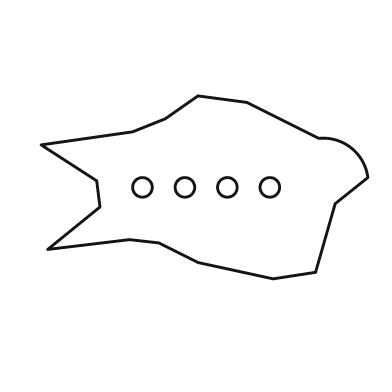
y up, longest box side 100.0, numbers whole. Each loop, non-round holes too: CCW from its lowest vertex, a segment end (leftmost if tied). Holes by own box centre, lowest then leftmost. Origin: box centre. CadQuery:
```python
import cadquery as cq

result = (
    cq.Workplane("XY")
    .moveTo(21.0, -28.0)
    .lineTo(34.0, -26.0)
    .lineTo(40.0, -5.0)
    .lineTo(50.0, 3.0)
    .threePointArc((45.0, 12.0), (35.0, 15.0))
    .lineTo(13.0, 26.0)
    .lineTo(-2.0, 28.0)
    .lineTo(-12.0, 21.0)
    .lineTo(-22.0, 17.0)
    .lineTo(-50.0, 13.0)
    .lineTo(-33.0, 2.0)
    .lineTo(-32.0, -6.0)
    .lineTo(-48.0, -19.0)
    .lineTo(-23.0, -16.0)
    .lineTo(-14.0, -17.0)
    .lineTo(-2.0, -23.0)
    .close()
    .moveTo(-19.0, 0.0)
    .circle(3.0)
    .moveTo(-6.0, 0.0)
    .circle(3.0)
    .moveTo(7.0, 0.0)
    .circle(3.0)
    .moveTo(20.0, 0.0)
    .circle(3.0)
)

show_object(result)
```